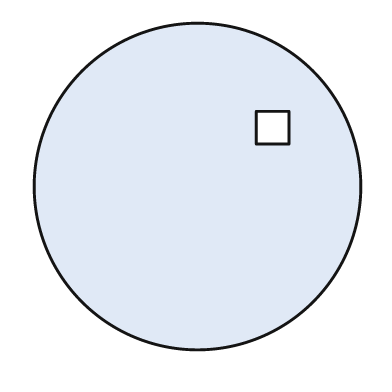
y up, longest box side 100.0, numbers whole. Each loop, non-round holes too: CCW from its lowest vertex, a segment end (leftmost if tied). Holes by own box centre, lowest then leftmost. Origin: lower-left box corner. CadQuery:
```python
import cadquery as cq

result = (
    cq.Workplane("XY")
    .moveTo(50.0, 50.0)
    .circle(50.0)
    .moveTo(68.0, 63.0)
    .lineTo(78.0, 63.0)
    .lineTo(78.0, 73.0)
    .lineTo(68.0, 73.0)
    .close()
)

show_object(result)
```